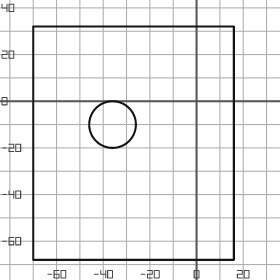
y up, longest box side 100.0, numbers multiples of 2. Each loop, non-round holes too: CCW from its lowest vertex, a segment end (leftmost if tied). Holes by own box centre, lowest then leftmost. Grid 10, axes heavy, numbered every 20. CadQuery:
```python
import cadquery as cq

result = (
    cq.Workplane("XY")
    .moveTo(-70.0, -68.0)
    .lineTo(16.0, -68.0)
    .lineTo(16.0, 32.0)
    .lineTo(-70.0, 32.0)
    .close()
    .moveTo(-36.0, -10.0)
    .circle(10.0)
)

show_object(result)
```